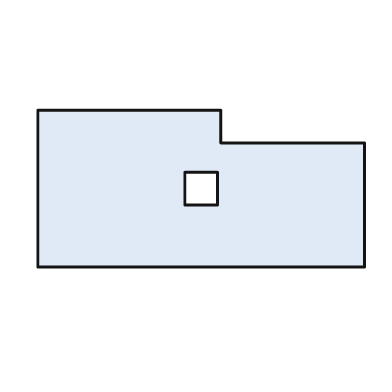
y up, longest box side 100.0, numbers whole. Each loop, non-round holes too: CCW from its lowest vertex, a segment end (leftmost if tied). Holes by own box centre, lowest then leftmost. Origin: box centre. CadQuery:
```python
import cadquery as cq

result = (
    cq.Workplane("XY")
    .moveTo(-50.0, -24.0)
    .lineTo(50.0, -24.0)
    .lineTo(50.0, 14.0)
    .lineTo(6.0, 14.0)
    .lineTo(6.0, 24.0)
    .lineTo(-50.0, 24.0)
    .close()
    .moveTo(-5.0, -5.0)
    .lineTo(5.0, -5.0)
    .lineTo(5.0, 5.0)
    .lineTo(-5.0, 5.0)
    .close()
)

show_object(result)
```